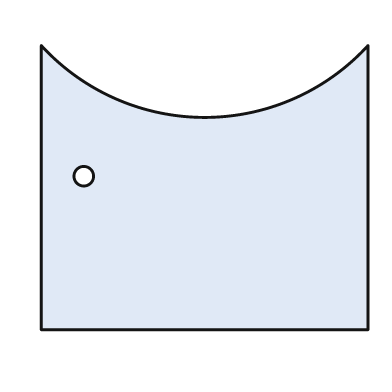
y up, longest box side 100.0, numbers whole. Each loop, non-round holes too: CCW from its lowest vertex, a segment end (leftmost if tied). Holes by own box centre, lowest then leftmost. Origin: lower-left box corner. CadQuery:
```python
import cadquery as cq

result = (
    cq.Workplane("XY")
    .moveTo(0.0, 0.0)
    .lineTo(100.0, 0.0)
    .lineTo(100.0, 87.0)
    .threePointArc((50.0, 65.0), (0.0, 87.0))
    .close()
    .moveTo(13.0, 47.0)
    .circle(3.0)
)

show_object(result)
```